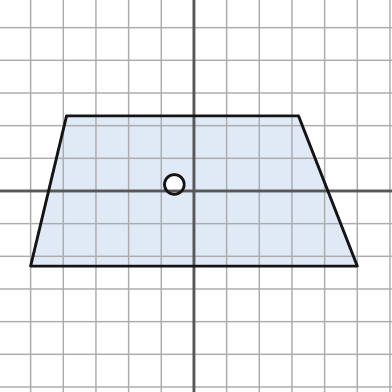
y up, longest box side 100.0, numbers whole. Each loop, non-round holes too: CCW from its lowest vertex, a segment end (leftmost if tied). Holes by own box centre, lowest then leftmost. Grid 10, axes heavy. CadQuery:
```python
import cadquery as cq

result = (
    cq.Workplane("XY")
    .moveTo(-50.0, -23.0)
    .lineTo(50.0, -23.0)
    .lineTo(32.0, 23.0)
    .lineTo(-39.0, 23.0)
    .close()
    .moveTo(-6.0, 2.0)
    .circle(3.0)
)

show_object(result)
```